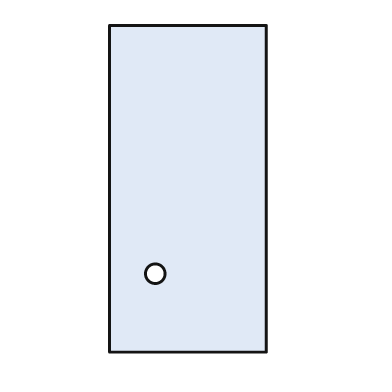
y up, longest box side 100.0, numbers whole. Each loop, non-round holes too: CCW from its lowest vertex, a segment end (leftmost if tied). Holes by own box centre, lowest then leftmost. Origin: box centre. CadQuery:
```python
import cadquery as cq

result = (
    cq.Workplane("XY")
    .moveTo(-24.0, -50.0)
    .lineTo(24.0, -50.0)
    .lineTo(24.0, 50.0)
    .lineTo(-24.0, 50.0)
    .close()
    .moveTo(-10.0, -26.0)
    .circle(3.0)
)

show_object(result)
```